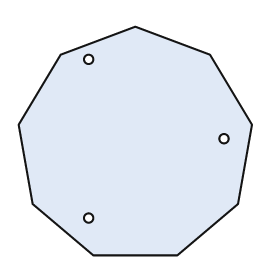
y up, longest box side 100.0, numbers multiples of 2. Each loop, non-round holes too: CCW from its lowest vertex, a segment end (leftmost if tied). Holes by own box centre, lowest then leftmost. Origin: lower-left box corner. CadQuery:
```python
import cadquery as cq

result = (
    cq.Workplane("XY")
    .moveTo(32.0, 0.0)
    .lineTo(68.0, 0.0)
    .lineTo(94.0, 22.0)
    .lineTo(100.0, 56.0)
    .lineTo(82.0, 86.0)
    .lineTo(50.0, 98.0)
    .lineTo(18.0, 86.0)
    .lineTo(0.0, 56.0)
    .lineTo(6.0, 22.0)
    .close()
    .moveTo(30.0, 16.0)
    .circle(2.0)
    .moveTo(88.0, 50.0)
    .circle(2.0)
    .moveTo(30.0, 84.0)
    .circle(2.0)
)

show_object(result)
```